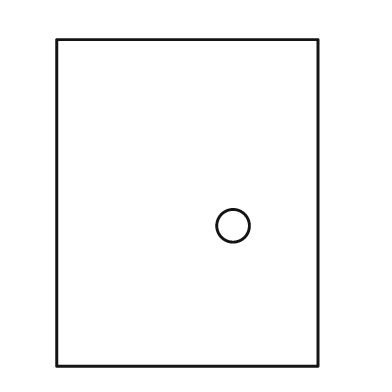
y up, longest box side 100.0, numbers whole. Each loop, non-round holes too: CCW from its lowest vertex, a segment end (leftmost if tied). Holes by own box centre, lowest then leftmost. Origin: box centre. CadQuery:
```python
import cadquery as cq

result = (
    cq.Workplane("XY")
    .moveTo(-40.0, -50.0)
    .lineTo(40.0, -50.0)
    .lineTo(40.0, 50.0)
    .lineTo(-40.0, 50.0)
    .close()
    .moveTo(14.0, -7.0)
    .circle(5.0)
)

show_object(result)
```